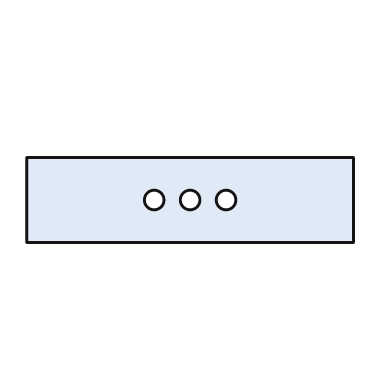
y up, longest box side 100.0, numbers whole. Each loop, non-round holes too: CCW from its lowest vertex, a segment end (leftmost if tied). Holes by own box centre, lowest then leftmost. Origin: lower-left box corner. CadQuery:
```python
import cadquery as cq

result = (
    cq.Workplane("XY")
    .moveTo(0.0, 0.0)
    .lineTo(100.0, 0.0)
    .lineTo(100.0, 26.0)
    .lineTo(0.0, 26.0)
    .close()
    .moveTo(39.0, 13.0)
    .circle(3.0)
    .moveTo(50.0, 13.0)
    .circle(3.0)
    .moveTo(61.0, 13.0)
    .circle(3.0)
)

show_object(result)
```